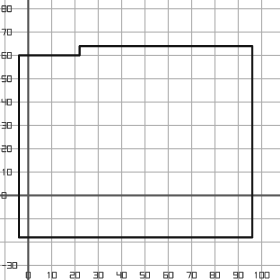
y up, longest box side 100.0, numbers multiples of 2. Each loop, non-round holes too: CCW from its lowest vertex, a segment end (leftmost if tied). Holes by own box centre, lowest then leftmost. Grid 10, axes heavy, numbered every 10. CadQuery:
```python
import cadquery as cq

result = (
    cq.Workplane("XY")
    .moveTo(-4.0, -18.0)
    .lineTo(96.0, -18.0)
    .lineTo(96.0, 64.0)
    .lineTo(22.0, 64.0)
    .lineTo(22.0, 60.0)
    .lineTo(-4.0, 60.0)
    .close()
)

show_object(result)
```